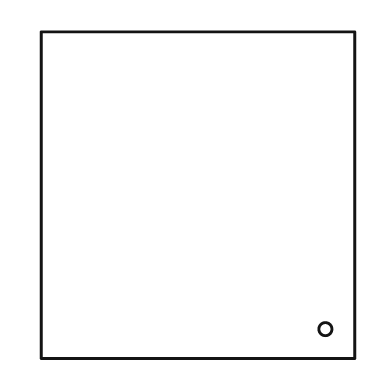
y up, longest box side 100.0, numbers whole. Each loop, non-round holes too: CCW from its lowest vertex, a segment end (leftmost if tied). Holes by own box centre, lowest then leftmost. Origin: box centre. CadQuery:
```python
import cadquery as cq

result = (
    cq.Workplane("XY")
    .moveTo(-48.0, -50.0)
    .lineTo(48.0, -50.0)
    .lineTo(48.0, 50.0)
    .lineTo(-48.0, 50.0)
    .close()
    .moveTo(39.0, -41.0)
    .circle(2.0)
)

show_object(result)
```